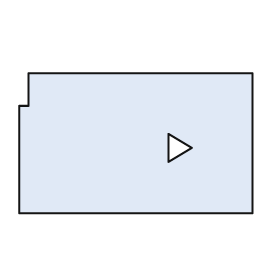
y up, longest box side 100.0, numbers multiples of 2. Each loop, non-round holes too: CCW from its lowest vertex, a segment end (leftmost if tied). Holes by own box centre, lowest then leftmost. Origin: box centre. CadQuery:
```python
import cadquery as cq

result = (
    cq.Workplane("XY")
    .moveTo(-50.0, -30.0)
    .lineTo(50.0, -30.0)
    .lineTo(50.0, 30.0)
    .lineTo(-46.0, 30.0)
    .lineTo(-46.0, 16.0)
    .lineTo(-50.0, 16.0)
    .close()
    .moveTo(14.0, -8.0)
    .lineTo(24.0, -2.0)
    .lineTo(14.0, 4.0)
    .close()
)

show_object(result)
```